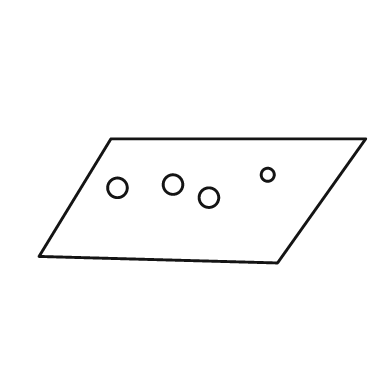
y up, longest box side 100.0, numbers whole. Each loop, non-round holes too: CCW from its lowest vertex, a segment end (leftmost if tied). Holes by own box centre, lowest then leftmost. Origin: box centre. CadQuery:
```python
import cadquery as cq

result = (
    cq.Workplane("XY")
    .moveTo(23.0, -19.0)
    .lineTo(50.0, 19.0)
    .lineTo(-28.0, 19.0)
    .lineTo(-50.0, -17.0)
    .close()
    .moveTo(2.0, 1.0)
    .circle(3.0)
    .moveTo(-26.0, 4.0)
    .circle(3.0)
    .moveTo(-9.0, 5.0)
    .circle(3.0)
    .moveTo(20.0, 8.0)
    .circle(2.0)
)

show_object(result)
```